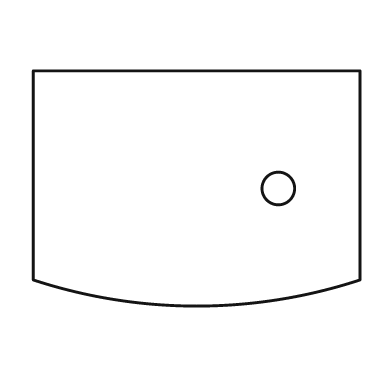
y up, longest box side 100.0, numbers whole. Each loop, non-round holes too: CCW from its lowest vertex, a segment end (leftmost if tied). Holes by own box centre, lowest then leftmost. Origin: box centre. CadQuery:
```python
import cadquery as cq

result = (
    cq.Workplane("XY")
    .moveTo(-50.0, -28.0)
    .threePointArc((0.0, -36.0), (50.0, -28.0))
    .lineTo(50.0, 36.0)
    .lineTo(-50.0, 36.0)
    .close()
    .moveTo(25.0, 0.0)
    .circle(5.0)
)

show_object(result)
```